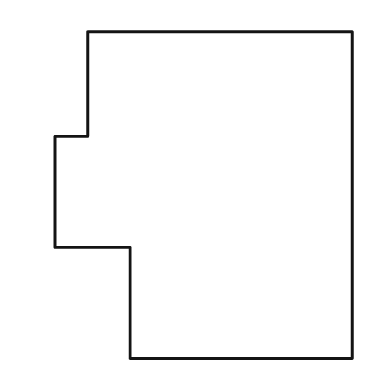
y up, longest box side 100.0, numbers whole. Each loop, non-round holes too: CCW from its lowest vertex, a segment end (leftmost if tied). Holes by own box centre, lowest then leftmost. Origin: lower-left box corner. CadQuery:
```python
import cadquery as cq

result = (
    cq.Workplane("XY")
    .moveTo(23.0, 0.0)
    .lineTo(91.0, 0.0)
    .lineTo(91.0, 100.0)
    .lineTo(10.0, 100.0)
    .lineTo(10.0, 68.0)
    .lineTo(0.0, 68.0)
    .lineTo(0.0, 34.0)
    .lineTo(23.0, 34.0)
    .close()
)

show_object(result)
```